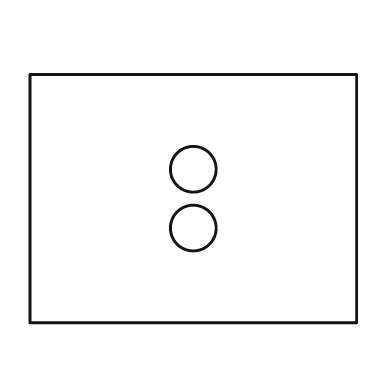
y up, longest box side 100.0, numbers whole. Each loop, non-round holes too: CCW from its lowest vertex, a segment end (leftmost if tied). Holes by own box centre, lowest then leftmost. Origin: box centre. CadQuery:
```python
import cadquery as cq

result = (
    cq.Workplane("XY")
    .moveTo(-50.0, -38.0)
    .lineTo(50.0, -38.0)
    .lineTo(50.0, 38.0)
    .lineTo(-50.0, 38.0)
    .close()
    .moveTo(0.0, -9.0)
    .circle(7.0)
    .moveTo(0.0, 9.0)
    .circle(7.0)
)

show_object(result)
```